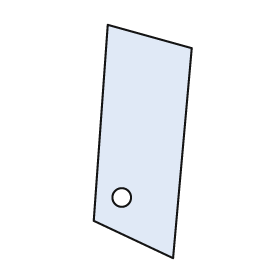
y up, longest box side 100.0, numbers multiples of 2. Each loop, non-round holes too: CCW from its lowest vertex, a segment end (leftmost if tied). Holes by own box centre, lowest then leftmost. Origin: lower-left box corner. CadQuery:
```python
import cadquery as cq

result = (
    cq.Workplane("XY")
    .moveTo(34.0, 0.0)
    .lineTo(42.0, 90.0)
    .lineTo(6.0, 100.0)
    .lineTo(0.0, 16.0)
    .close()
    .moveTo(12.0, 26.0)
    .circle(4.0)
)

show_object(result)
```